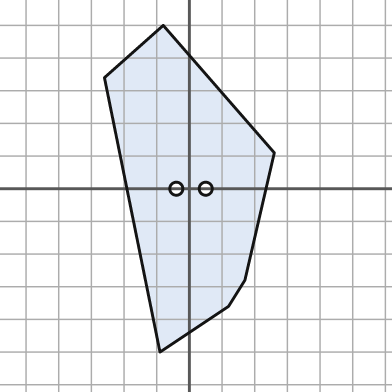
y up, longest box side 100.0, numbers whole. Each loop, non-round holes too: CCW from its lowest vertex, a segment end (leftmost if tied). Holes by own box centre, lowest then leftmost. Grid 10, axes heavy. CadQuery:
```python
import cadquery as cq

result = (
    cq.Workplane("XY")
    .moveTo(-9.0, -50.0)
    .lineTo(12.0, -36.0)
    .lineTo(17.0, -28.0)
    .lineTo(26.0, 11.0)
    .lineTo(-8.0, 50.0)
    .lineTo(-26.0, 34.0)
    .close()
    .moveTo(-4.0, 0.0)
    .circle(2.0)
    .moveTo(5.0, 0.0)
    .circle(2.0)
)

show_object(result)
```